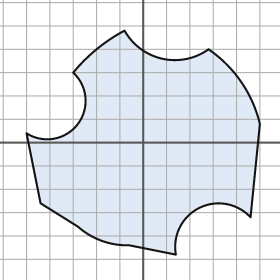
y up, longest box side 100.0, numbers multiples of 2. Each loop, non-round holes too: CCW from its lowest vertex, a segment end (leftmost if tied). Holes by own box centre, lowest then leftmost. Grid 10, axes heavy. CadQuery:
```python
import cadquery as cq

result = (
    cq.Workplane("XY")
    .moveTo(14.0, -48.0)
    .threePointArc((24.0, -28.0), (46.0, -32.0))
    .lineTo(50.0, 8.0)
    .threePointArc((42.0, 26.0), (28.0, 40.0))
    .threePointArc((8.0, 36.0), (-8.0, 48.0))
    .threePointArc((-20.0, 40.0), (-30.0, 30.0))
    .threePointArc((-28.0, 8.0), (-50.0, 4.0))
    .lineTo(-44.0, -26.0)
    .lineTo(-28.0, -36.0)
    .threePointArc((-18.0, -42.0), (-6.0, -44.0))
    .close()
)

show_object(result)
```